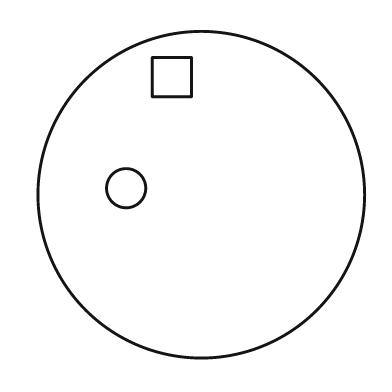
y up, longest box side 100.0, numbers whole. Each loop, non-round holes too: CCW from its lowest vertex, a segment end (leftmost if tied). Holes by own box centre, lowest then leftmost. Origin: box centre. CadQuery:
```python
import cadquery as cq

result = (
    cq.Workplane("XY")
    .moveTo(0.0, 0.0)
    .circle(50.0)
    .moveTo(-23.0, 2.0)
    .circle(6.0)
    .moveTo(-15.0, 30.0)
    .lineTo(-3.0, 30.0)
    .lineTo(-3.0, 42.0)
    .lineTo(-15.0, 42.0)
    .close()
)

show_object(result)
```